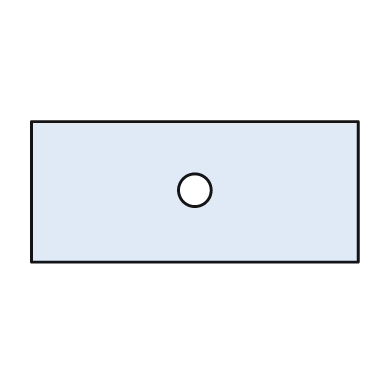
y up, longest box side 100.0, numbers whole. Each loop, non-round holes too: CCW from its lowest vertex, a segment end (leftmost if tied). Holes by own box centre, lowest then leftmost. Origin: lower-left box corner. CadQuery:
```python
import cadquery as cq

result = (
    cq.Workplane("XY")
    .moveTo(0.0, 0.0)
    .lineTo(100.0, 0.0)
    .lineTo(100.0, 43.0)
    .lineTo(0.0, 43.0)
    .close()
    .moveTo(50.0, 22.0)
    .circle(5.0)
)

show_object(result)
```